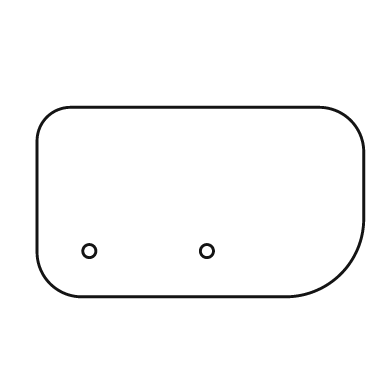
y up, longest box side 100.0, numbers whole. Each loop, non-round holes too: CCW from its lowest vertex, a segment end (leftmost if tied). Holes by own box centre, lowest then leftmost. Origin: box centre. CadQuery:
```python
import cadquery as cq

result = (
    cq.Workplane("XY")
    .moveTo(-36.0, -29.0)
    .lineTo(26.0, -29.0)
    .threePointArc((43.0, -22.0), (50.0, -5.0))
    .lineTo(50.0, 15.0)
    .threePointArc((46.0, 25.0), (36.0, 29.0))
    .lineTo(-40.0, 29.0)
    .threePointArc((-47.0, 26.0), (-50.0, 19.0))
    .lineTo(-50.0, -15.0)
    .threePointArc((-46.0, -25.0), (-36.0, -29.0))
    .close()
    .moveTo(-34.0, -15.0)
    .circle(2.0)
    .moveTo(2.0, -15.0)
    .circle(2.0)
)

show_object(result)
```